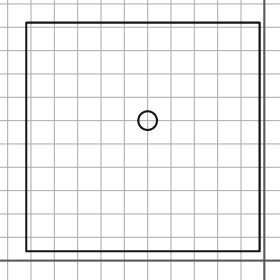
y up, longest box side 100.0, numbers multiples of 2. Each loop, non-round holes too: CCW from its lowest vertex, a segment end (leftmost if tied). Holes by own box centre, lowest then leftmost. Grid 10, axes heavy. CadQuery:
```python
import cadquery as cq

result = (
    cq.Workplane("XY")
    .moveTo(-102.0, 4.0)
    .lineTo(-2.0, 4.0)
    .lineTo(-2.0, 102.0)
    .lineTo(-102.0, 102.0)
    .close()
    .moveTo(-50.0, 60.0)
    .circle(4.0)
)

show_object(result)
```